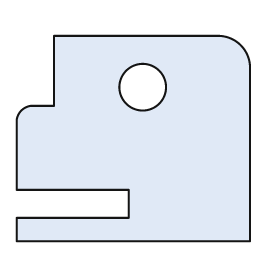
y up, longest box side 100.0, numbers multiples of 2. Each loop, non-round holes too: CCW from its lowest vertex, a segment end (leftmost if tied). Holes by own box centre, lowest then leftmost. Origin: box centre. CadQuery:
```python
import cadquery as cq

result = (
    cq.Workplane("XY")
    .moveTo(-50.0, -44.0)
    .lineTo(50.0, -44.0)
    .lineTo(50.0, 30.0)
    .threePointArc((46.0, 40.0), (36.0, 44.0))
    .lineTo(-34.0, 44.0)
    .lineTo(-34.0, 14.0)
    .lineTo(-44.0, 14.0)
    .threePointArc((-48.0, 12.0), (-50.0, 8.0))
    .lineTo(-50.0, -22.0)
    .lineTo(-2.0, -22.0)
    .lineTo(-2.0, -34.0)
    .lineTo(-50.0, -34.0)
    .close()
    .moveTo(4.0, 22.0)
    .circle(10.0)
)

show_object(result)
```